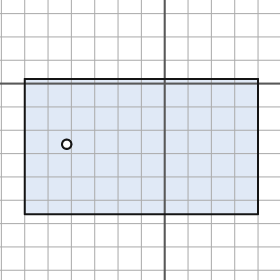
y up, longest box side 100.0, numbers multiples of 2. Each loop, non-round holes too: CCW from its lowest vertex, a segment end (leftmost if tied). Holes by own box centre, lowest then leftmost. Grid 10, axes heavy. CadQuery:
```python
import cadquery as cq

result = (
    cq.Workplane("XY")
    .moveTo(-60.0, -56.0)
    .lineTo(40.0, -56.0)
    .lineTo(40.0, 2.0)
    .lineTo(-60.0, 2.0)
    .close()
    .moveTo(-42.0, -26.0)
    .circle(2.0)
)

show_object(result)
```